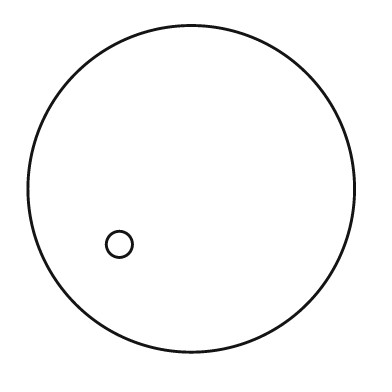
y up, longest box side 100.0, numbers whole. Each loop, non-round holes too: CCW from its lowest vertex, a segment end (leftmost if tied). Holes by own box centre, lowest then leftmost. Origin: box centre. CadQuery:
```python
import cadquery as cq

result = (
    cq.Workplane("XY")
    .moveTo(0.0, 0.0)
    .circle(50.0)
    .moveTo(-22.0, -17.0)
    .circle(4.0)
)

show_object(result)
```